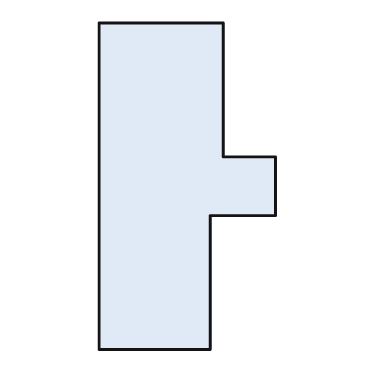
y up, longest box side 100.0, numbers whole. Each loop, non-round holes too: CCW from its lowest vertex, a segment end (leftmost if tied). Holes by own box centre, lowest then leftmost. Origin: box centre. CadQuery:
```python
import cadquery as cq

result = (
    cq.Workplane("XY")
    .moveTo(-27.0, -50.0)
    .lineTo(7.0, -50.0)
    .lineTo(7.0, -9.0)
    .lineTo(27.0, -9.0)
    .lineTo(27.0, 9.0)
    .lineTo(11.0, 9.0)
    .lineTo(11.0, 50.0)
    .lineTo(-27.0, 50.0)
    .close()
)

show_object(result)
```